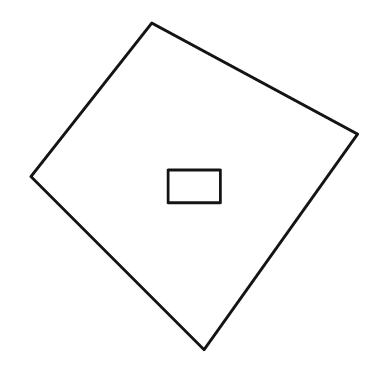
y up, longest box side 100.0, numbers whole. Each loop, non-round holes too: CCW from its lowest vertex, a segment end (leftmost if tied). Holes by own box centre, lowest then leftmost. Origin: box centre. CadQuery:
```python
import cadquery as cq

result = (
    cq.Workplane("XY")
    .moveTo(3.0, -50.0)
    .lineTo(50.0, 16.0)
    .lineTo(-13.0, 50.0)
    .lineTo(-50.0, 3.0)
    .close()
    .moveTo(-8.0, -5.0)
    .lineTo(8.0, -5.0)
    .lineTo(8.0, 5.0)
    .lineTo(-8.0, 5.0)
    .close()
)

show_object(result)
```